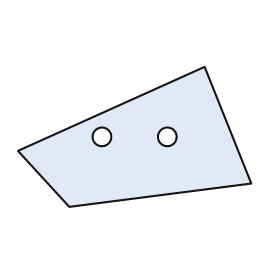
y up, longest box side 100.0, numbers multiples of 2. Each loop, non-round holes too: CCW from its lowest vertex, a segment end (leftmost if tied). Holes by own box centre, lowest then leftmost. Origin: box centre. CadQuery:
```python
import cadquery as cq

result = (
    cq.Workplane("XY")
    .moveTo(-28.0, -30.0)
    .lineTo(50.0, -20.0)
    .lineTo(30.0, 30.0)
    .lineTo(-50.0, -6.0)
    .close()
    .moveTo(-14.0, 0.0)
    .circle(4.0)
    .moveTo(14.0, 0.0)
    .circle(4.0)
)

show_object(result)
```